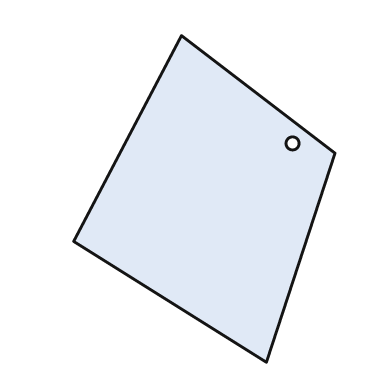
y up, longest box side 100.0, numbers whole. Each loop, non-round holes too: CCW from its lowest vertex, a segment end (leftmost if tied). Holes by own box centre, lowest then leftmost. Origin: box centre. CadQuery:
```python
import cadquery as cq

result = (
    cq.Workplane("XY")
    .moveTo(19.0, -50.0)
    .lineTo(40.0, 14.0)
    .lineTo(-7.0, 50.0)
    .lineTo(-40.0, -13.0)
    .close()
    .moveTo(27.0, 17.0)
    .circle(2.0)
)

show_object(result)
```